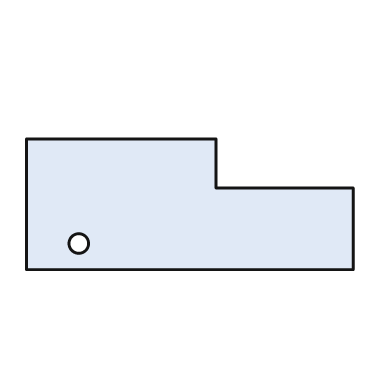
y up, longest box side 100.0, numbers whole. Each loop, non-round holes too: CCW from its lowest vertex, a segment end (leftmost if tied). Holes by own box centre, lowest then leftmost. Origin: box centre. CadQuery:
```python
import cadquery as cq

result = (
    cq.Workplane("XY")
    .moveTo(-50.0, -20.0)
    .lineTo(50.0, -20.0)
    .lineTo(50.0, 5.0)
    .lineTo(8.0, 5.0)
    .lineTo(8.0, 20.0)
    .lineTo(-50.0, 20.0)
    .close()
    .moveTo(-34.0, -12.0)
    .circle(3.0)
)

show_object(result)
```